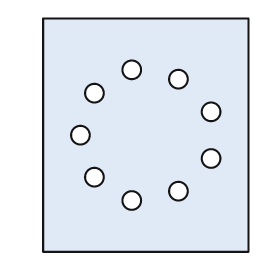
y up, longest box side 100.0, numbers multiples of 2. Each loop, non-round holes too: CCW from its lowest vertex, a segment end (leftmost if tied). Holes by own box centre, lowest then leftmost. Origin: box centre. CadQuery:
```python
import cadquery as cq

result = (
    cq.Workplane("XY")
    .moveTo(-44.0, -50.0)
    .lineTo(44.0, -50.0)
    .lineTo(44.0, 50.0)
    .lineTo(-44.0, 50.0)
    .close()
    .moveTo(-6.0, -28.0)
    .circle(4.0)
    .moveTo(14.0, -24.0)
    .circle(4.0)
    .moveTo(-22.0, -18.0)
    .circle(4.0)
    .moveTo(28.0, -10.0)
    .circle(4.0)
    .moveTo(-28.0, 0.0)
    .circle(4.0)
    .moveTo(28.0, 10.0)
    .circle(4.0)
    .moveTo(-22.0, 18.0)
    .circle(4.0)
    .moveTo(14.0, 24.0)
    .circle(4.0)
    .moveTo(-6.0, 28.0)
    .circle(4.0)
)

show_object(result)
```